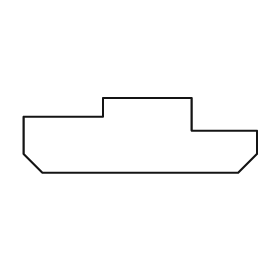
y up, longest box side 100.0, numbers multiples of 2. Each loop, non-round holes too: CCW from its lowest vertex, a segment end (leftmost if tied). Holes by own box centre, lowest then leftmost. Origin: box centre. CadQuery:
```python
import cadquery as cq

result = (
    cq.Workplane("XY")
    .moveTo(-42.0, -16.0)
    .lineTo(42.0, -16.0)
    .lineTo(50.0, -8.0)
    .lineTo(50.0, 2.0)
    .lineTo(22.0, 2.0)
    .lineTo(22.0, 16.0)
    .lineTo(-16.0, 16.0)
    .lineTo(-16.0, 8.0)
    .lineTo(-50.0, 8.0)
    .lineTo(-50.0, -8.0)
    .close()
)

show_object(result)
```